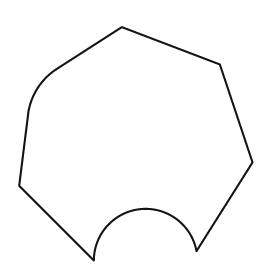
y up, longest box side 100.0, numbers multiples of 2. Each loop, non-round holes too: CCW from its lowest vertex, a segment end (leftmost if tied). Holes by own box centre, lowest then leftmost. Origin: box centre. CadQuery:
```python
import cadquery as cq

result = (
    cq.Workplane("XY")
    .moveTo(-18.0, -50.0)
    .threePointArc((2.0, -28.0), (26.0, -46.0))
    .lineTo(50.0, -8.0)
    .lineTo(36.0, 34.0)
    .lineTo(-6.0, 50.0)
    .lineTo(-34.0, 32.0)
    .threePointArc((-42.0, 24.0), (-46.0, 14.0))
    .lineTo(-50.0, -18.0)
    .close()
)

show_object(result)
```